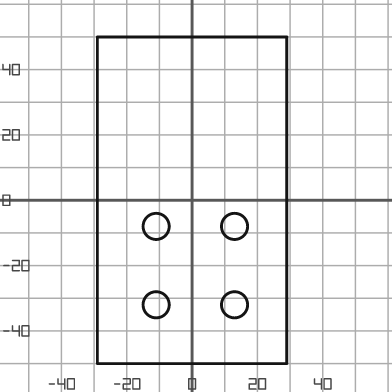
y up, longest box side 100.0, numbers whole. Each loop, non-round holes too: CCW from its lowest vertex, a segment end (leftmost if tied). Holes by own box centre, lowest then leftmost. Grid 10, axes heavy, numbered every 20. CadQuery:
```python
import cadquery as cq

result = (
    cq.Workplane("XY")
    .moveTo(-29.0, -50.0)
    .lineTo(29.0, -50.0)
    .lineTo(29.0, 50.0)
    .lineTo(-29.0, 50.0)
    .close()
    .moveTo(-11.0, -32.0)
    .circle(4.0)
    .moveTo(13.0, -32.0)
    .circle(4.0)
    .moveTo(-11.0, -8.0)
    .circle(4.0)
    .moveTo(13.0, -8.0)
    .circle(4.0)
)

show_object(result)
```